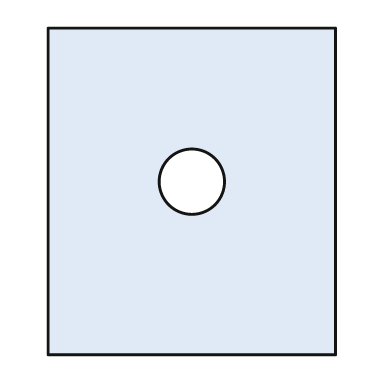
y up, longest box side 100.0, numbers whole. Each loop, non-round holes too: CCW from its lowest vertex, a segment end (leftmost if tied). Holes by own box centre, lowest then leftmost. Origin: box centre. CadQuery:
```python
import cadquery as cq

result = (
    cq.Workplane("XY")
    .moveTo(-44.0, -50.0)
    .lineTo(44.0, -50.0)
    .lineTo(44.0, 50.0)
    .lineTo(-44.0, 50.0)
    .close()
    .moveTo(0.0, 3.0)
    .circle(10.0)
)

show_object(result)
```